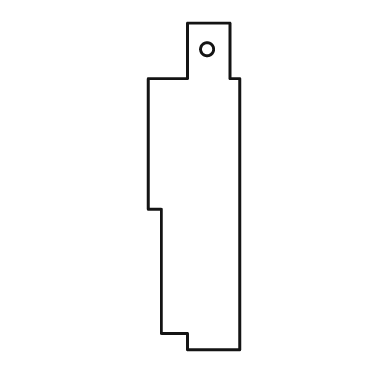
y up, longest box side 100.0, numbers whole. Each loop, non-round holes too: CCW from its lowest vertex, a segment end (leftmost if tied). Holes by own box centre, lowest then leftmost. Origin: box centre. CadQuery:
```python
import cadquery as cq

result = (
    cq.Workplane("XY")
    .moveTo(-2.0, -50.0)
    .lineTo(14.0, -50.0)
    .lineTo(14.0, 33.0)
    .lineTo(11.0, 33.0)
    .lineTo(11.0, 50.0)
    .lineTo(-2.0, 50.0)
    .lineTo(-2.0, 33.0)
    .lineTo(-14.0, 33.0)
    .lineTo(-14.0, -7.0)
    .lineTo(-10.0, -7.0)
    .lineTo(-10.0, -45.0)
    .lineTo(-2.0, -45.0)
    .close()
    .moveTo(4.0, 42.0)
    .circle(2.0)
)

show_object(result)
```